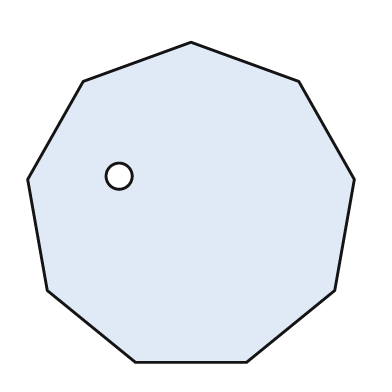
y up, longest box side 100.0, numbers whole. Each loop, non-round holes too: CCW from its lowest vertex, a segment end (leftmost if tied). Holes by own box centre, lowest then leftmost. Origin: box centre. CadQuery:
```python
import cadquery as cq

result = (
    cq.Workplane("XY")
    .moveTo(-17.0, -49.0)
    .lineTo(17.0, -49.0)
    .lineTo(44.0, -27.0)
    .lineTo(50.0, 7.0)
    .lineTo(33.0, 37.0)
    .lineTo(0.0, 49.0)
    .lineTo(-33.0, 37.0)
    .lineTo(-50.0, 7.0)
    .lineTo(-44.0, -27.0)
    .close()
    .moveTo(-22.0, 8.0)
    .circle(4.0)
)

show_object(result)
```